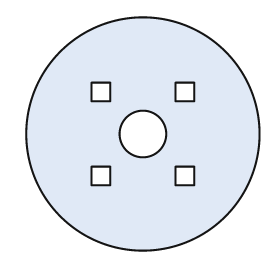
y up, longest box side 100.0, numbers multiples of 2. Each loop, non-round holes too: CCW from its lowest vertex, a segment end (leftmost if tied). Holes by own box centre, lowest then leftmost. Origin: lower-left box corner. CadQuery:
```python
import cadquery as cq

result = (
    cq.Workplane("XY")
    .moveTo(50.0, 50.0)
    .circle(50.0)
    .moveTo(28.0, 28.0)
    .lineTo(36.0, 28.0)
    .lineTo(36.0, 36.0)
    .lineTo(28.0, 36.0)
    .close()
    .moveTo(64.0, 28.0)
    .lineTo(72.0, 28.0)
    .lineTo(72.0, 36.0)
    .lineTo(64.0, 36.0)
    .close()
    .moveTo(50.0, 50.0)
    .circle(10.0)
    .moveTo(28.0, 64.0)
    .lineTo(36.0, 64.0)
    .lineTo(36.0, 72.0)
    .lineTo(28.0, 72.0)
    .close()
    .moveTo(64.0, 64.0)
    .lineTo(72.0, 64.0)
    .lineTo(72.0, 72.0)
    .lineTo(64.0, 72.0)
    .close()
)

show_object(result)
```